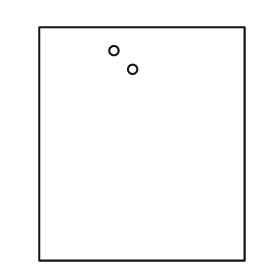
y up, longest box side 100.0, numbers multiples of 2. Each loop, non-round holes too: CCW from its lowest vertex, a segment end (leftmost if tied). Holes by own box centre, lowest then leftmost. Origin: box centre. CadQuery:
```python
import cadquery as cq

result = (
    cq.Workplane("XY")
    .moveTo(-44.0, -50.0)
    .lineTo(44.0, -50.0)
    .lineTo(44.0, 50.0)
    .lineTo(-44.0, 50.0)
    .close()
    .moveTo(-4.0, 32.0)
    .circle(2.0)
    .moveTo(-12.0, 40.0)
    .circle(2.0)
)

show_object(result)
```